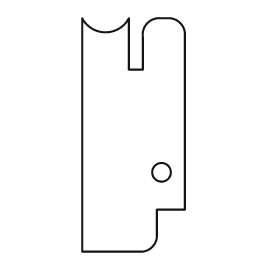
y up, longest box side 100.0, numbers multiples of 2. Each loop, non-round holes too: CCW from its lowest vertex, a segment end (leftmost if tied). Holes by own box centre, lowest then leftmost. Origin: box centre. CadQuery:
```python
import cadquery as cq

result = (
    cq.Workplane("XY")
    .moveTo(-22.0, -50.0)
    .lineTo(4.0, -50.0)
    .threePointArc((8.0, -48.0), (10.0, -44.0))
    .lineTo(10.0, -32.0)
    .lineTo(22.0, -32.0)
    .lineTo(22.0, 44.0)
    .threePointArc((20.0, 48.0), (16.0, 50.0))
    .lineTo(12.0, 50.0)
    .threePointArc((6.0, 48.0), (4.0, 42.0))
    .lineTo(4.0, 28.0)
    .lineTo(-2.0, 28.0)
    .lineTo(-2.0, 50.0)
    .threePointArc((-12.0, 44.0), (-22.0, 50.0))
    .close()
    .moveTo(12.0, -16.0)
    .circle(4.0)
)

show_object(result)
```